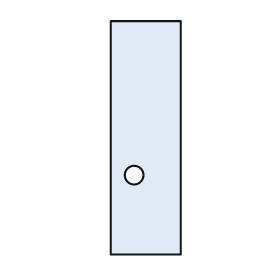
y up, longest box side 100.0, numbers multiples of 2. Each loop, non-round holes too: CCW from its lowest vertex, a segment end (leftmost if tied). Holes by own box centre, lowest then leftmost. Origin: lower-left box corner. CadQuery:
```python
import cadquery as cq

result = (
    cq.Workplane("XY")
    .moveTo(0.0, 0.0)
    .lineTo(30.0, 0.0)
    .lineTo(30.0, 100.0)
    .lineTo(0.0, 100.0)
    .close()
    .moveTo(10.0, 34.0)
    .circle(4.0)
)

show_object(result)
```